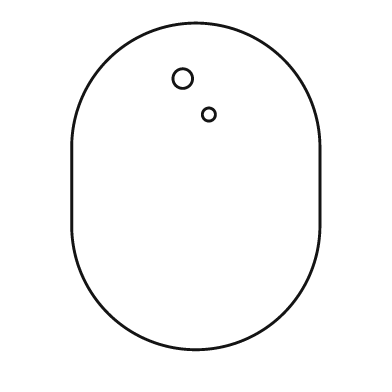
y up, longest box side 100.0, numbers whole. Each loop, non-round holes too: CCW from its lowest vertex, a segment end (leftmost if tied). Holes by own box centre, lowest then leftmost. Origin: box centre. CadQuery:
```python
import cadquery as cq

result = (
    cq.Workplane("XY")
    .moveTo(-38.0, -12.0)
    .threePointArc((0.0, -50.0), (38.0, -12.0))
    .lineTo(38.0, 12.0)
    .threePointArc((0.0, 50.0), (-38.0, 12.0))
    .close()
    .moveTo(4.0, 22.0)
    .circle(2.0)
    .moveTo(-4.0, 33.0)
    .circle(3.0)
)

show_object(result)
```